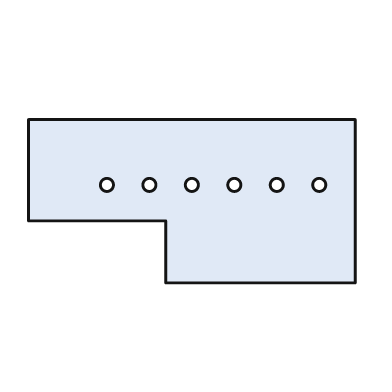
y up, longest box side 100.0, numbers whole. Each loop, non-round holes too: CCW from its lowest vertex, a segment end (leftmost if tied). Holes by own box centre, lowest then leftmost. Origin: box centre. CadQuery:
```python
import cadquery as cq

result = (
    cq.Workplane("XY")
    .moveTo(-8.0, -25.0)
    .lineTo(50.0, -25.0)
    .lineTo(50.0, 25.0)
    .lineTo(-50.0, 25.0)
    .lineTo(-50.0, -6.0)
    .lineTo(-8.0, -6.0)
    .close()
    .moveTo(-26.0, 5.0)
    .circle(2.0)
    .moveTo(-13.0, 5.0)
    .circle(2.0)
    .moveTo(0.0, 5.0)
    .circle(2.0)
    .moveTo(13.0, 5.0)
    .circle(2.0)
    .moveTo(26.0, 5.0)
    .circle(2.0)
    .moveTo(39.0, 5.0)
    .circle(2.0)
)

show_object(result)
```